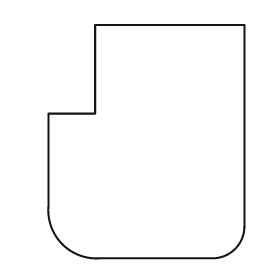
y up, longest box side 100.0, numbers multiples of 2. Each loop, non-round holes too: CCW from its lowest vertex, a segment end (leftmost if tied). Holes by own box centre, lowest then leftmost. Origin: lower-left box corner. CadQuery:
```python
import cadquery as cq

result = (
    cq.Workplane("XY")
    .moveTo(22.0, 0.0)
    .lineTo(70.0, 0.0)
    .threePointArc((80.0, 4.0), (84.0, 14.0))
    .lineTo(84.0, 100.0)
    .lineTo(20.0, 100.0)
    .lineTo(20.0, 62.0)
    .lineTo(0.0, 62.0)
    .lineTo(0.0, 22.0)
    .threePointArc((6.0, 6.0), (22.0, 0.0))
    .close()
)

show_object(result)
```